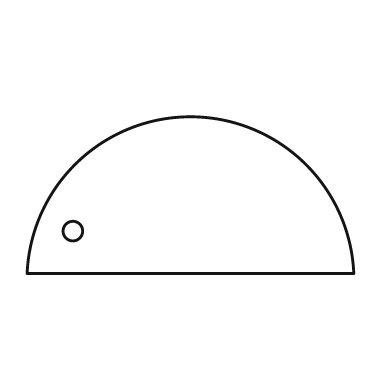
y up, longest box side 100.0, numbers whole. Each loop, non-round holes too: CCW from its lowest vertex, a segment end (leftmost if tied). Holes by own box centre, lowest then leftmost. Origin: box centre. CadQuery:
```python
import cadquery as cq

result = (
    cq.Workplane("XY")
    .moveTo(-50.0, -24.0)
    .lineTo(50.0, -24.0)
    .threePointArc((0.0, 24.0), (-50.0, -24.0))
    .close()
    .moveTo(-36.0, -11.0)
    .circle(3.0)
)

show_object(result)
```